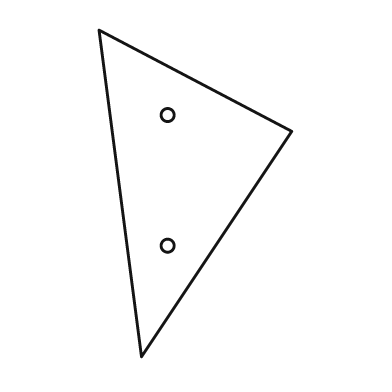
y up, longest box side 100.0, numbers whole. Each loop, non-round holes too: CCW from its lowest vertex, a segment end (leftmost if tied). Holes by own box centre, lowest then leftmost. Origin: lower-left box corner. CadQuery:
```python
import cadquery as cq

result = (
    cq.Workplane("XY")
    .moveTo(13.0, 0.0)
    .lineTo(59.0, 69.0)
    .lineTo(0.0, 100.0)
    .close()
    .moveTo(21.0, 34.0)
    .circle(2.0)
    .moveTo(21.0, 74.0)
    .circle(2.0)
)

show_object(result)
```